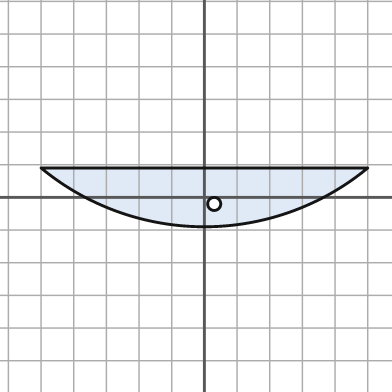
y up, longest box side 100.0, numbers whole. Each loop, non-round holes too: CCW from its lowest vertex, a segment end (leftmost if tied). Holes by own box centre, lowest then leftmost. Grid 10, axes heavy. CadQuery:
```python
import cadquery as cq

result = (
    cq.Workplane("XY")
    .moveTo(-50.0, 9.0)
    .threePointArc((0.0, -9.0), (50.0, 9.0))
    .close()
    .moveTo(3.0, -2.0)
    .circle(2.0)
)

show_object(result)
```